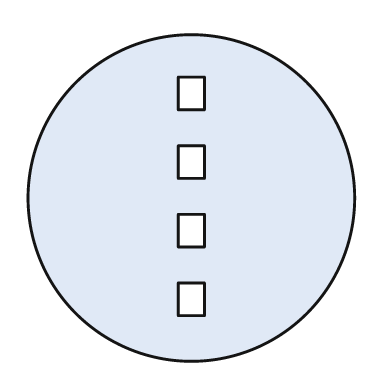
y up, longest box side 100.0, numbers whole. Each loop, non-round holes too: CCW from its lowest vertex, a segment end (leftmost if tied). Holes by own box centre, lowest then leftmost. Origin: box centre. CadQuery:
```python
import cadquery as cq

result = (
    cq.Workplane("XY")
    .moveTo(0.0, 0.0)
    .circle(50.0)
    .moveTo(-4.0, -36.0)
    .lineTo(4.0, -36.0)
    .lineTo(4.0, -26.0)
    .lineTo(-4.0, -26.0)
    .close()
    .moveTo(-4.0, -15.0)
    .lineTo(4.0, -15.0)
    .lineTo(4.0, -5.0)
    .lineTo(-4.0, -5.0)
    .close()
    .moveTo(-4.0, 6.0)
    .lineTo(4.0, 6.0)
    .lineTo(4.0, 16.0)
    .lineTo(-4.0, 16.0)
    .close()
    .moveTo(-4.0, 27.0)
    .lineTo(4.0, 27.0)
    .lineTo(4.0, 37.0)
    .lineTo(-4.0, 37.0)
    .close()
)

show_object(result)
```